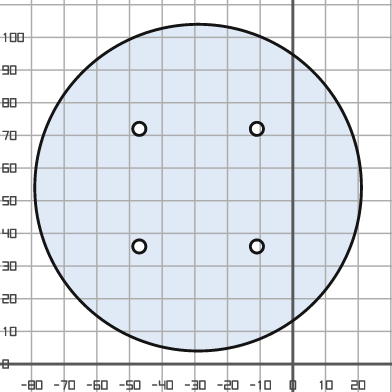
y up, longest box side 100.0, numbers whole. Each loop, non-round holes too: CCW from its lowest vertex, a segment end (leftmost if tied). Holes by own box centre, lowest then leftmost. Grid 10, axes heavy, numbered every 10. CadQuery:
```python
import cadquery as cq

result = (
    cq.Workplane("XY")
    .moveTo(-29.0, 54.0)
    .circle(50.0)
    .moveTo(-47.0, 36.0)
    .circle(2.0)
    .moveTo(-11.0, 36.0)
    .circle(2.0)
    .moveTo(-47.0, 72.0)
    .circle(2.0)
    .moveTo(-11.0, 72.0)
    .circle(2.0)
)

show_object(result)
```